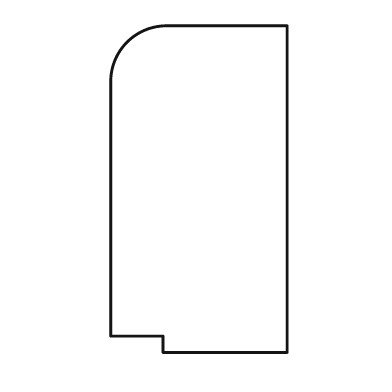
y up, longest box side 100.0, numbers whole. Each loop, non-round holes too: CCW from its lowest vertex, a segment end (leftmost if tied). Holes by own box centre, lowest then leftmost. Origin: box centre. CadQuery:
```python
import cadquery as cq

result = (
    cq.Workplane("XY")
    .moveTo(-11.0, -50.0)
    .lineTo(27.0, -50.0)
    .lineTo(27.0, 50.0)
    .lineTo(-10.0, 50.0)
    .threePointArc((-22.0, 45.0), (-27.0, 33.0))
    .lineTo(-27.0, -45.0)
    .lineTo(-11.0, -45.0)
    .close()
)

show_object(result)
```